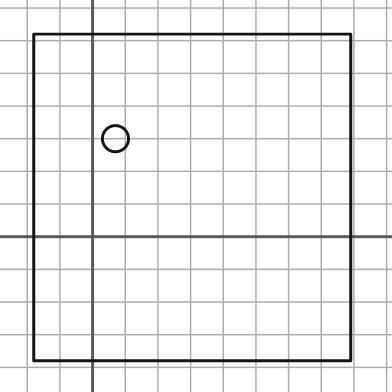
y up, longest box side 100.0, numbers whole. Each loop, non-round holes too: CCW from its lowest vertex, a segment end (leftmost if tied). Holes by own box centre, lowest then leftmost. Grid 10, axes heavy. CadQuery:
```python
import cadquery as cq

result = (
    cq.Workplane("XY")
    .moveTo(-18.0, -38.0)
    .lineTo(79.0, -38.0)
    .lineTo(79.0, 62.0)
    .lineTo(-18.0, 62.0)
    .close()
    .moveTo(7.0, 30.0)
    .circle(4.0)
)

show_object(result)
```